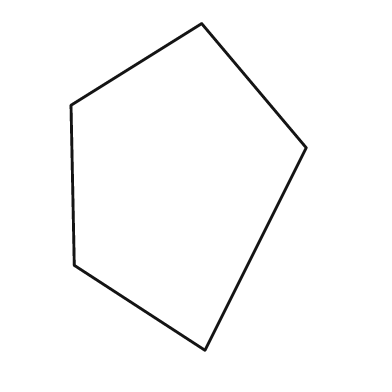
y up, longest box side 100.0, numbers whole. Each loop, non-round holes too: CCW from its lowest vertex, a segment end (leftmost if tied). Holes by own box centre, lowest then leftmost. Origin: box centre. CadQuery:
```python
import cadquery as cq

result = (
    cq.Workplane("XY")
    .moveTo(5.0, -50.0)
    .lineTo(36.0, 12.0)
    .lineTo(4.0, 50.0)
    .lineTo(-36.0, 25.0)
    .lineTo(-35.0, -24.0)
    .close()
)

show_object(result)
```